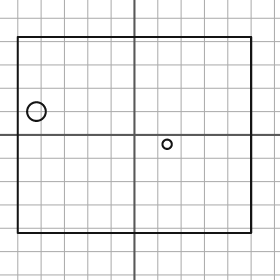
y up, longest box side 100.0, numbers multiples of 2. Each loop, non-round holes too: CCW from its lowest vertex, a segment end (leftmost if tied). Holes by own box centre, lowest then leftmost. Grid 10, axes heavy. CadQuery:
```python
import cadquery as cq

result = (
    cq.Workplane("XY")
    .moveTo(-50.0, -42.0)
    .lineTo(50.0, -42.0)
    .lineTo(50.0, 42.0)
    .lineTo(-50.0, 42.0)
    .close()
    .moveTo(14.0, -4.0)
    .circle(2.0)
    .moveTo(-42.0, 10.0)
    .circle(4.0)
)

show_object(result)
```